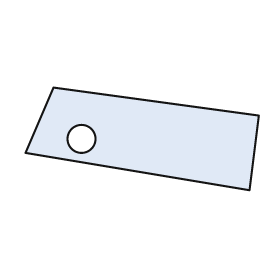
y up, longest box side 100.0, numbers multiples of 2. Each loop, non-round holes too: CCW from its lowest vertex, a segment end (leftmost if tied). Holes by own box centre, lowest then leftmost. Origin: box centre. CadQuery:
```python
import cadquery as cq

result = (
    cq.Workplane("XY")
    .moveTo(46.0, -22.0)
    .lineTo(50.0, 10.0)
    .lineTo(-38.0, 22.0)
    .lineTo(-50.0, -6.0)
    .close()
    .moveTo(-26.0, 0.0)
    .circle(6.0)
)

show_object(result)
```